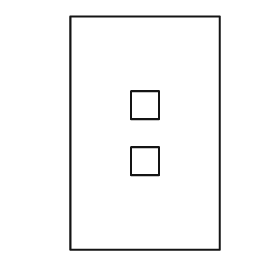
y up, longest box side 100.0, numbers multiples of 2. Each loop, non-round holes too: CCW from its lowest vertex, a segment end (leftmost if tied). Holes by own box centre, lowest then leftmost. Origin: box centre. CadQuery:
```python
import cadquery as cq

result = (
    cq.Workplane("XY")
    .moveTo(-32.0, -50.0)
    .lineTo(32.0, -50.0)
    .lineTo(32.0, 50.0)
    .lineTo(-32.0, 50.0)
    .close()
    .moveTo(-6.0, -18.0)
    .lineTo(6.0, -18.0)
    .lineTo(6.0, -6.0)
    .lineTo(-6.0, -6.0)
    .close()
    .moveTo(-6.0, 6.0)
    .lineTo(6.0, 6.0)
    .lineTo(6.0, 18.0)
    .lineTo(-6.0, 18.0)
    .close()
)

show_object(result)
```